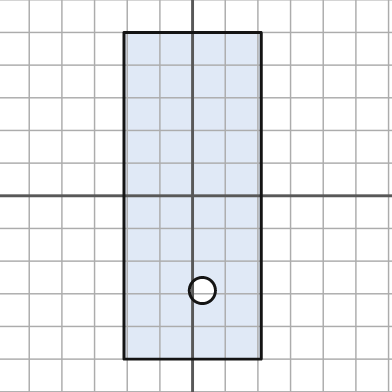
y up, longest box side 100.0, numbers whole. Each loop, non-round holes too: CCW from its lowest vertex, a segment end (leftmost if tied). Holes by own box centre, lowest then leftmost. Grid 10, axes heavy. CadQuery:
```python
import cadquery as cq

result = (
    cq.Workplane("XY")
    .moveTo(-21.0, -50.0)
    .lineTo(21.0, -50.0)
    .lineTo(21.0, 50.0)
    .lineTo(-21.0, 50.0)
    .close()
    .moveTo(3.0, -29.0)
    .circle(4.0)
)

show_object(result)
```